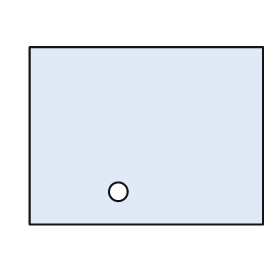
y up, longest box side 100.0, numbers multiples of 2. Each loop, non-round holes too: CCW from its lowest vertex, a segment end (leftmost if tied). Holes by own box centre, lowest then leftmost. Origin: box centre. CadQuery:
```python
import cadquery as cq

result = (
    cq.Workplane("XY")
    .moveTo(-50.0, -38.0)
    .lineTo(50.0, -38.0)
    .lineTo(50.0, 38.0)
    .lineTo(-50.0, 38.0)
    .close()
    .moveTo(-12.0, -24.0)
    .circle(4.0)
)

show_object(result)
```